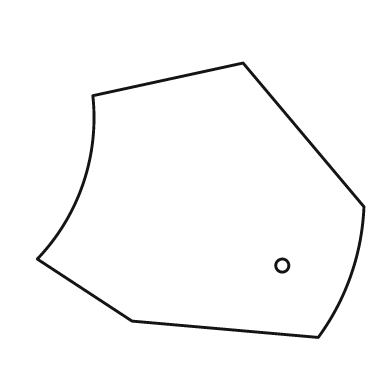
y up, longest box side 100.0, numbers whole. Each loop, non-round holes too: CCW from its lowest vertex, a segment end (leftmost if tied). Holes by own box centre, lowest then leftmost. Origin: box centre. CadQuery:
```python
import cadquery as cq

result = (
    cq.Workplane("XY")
    .moveTo(36.0, -42.0)
    .threePointArc((46.0, -23.0), (50.0, -2.0))
    .lineTo(13.0, 42.0)
    .lineTo(-33.0, 32.0)
    .threePointArc((-36.0, 5.0), (-50.0, -18.0))
    .lineTo(-21.0, -37.0)
    .close()
    .moveTo(25.0, -20.0)
    .circle(2.0)
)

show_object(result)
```